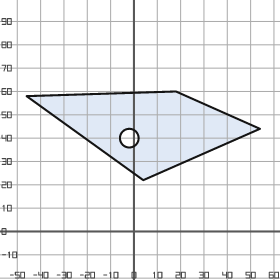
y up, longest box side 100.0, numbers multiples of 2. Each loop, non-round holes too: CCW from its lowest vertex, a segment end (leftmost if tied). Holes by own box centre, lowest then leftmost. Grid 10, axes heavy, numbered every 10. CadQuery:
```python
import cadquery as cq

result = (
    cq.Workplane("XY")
    .moveTo(4.0, 22.0)
    .lineTo(54.0, 44.0)
    .lineTo(18.0, 60.0)
    .lineTo(-46.0, 58.0)
    .close()
    .moveTo(-2.0, 40.0)
    .circle(4.0)
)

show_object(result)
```